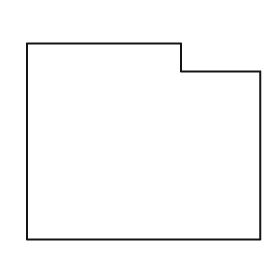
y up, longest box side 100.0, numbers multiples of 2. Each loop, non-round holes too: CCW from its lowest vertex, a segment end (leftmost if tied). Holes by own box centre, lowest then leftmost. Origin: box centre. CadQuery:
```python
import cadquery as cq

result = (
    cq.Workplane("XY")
    .moveTo(-50.0, -42.0)
    .lineTo(50.0, -42.0)
    .lineTo(50.0, 30.0)
    .lineTo(16.0, 30.0)
    .lineTo(16.0, 42.0)
    .lineTo(-50.0, 42.0)
    .close()
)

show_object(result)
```